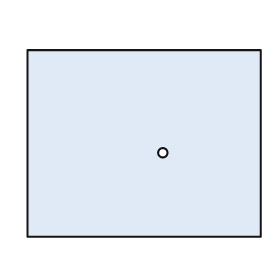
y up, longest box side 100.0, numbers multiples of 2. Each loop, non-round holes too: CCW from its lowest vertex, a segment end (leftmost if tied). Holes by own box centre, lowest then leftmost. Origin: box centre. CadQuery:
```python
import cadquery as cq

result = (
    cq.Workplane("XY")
    .moveTo(-50.0, -40.0)
    .lineTo(50.0, -40.0)
    .lineTo(50.0, 40.0)
    .lineTo(-50.0, 40.0)
    .close()
    .moveTo(8.0, -4.0)
    .circle(2.0)
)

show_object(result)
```